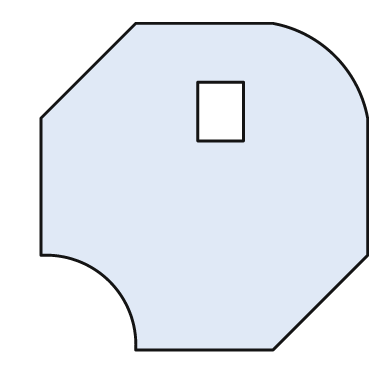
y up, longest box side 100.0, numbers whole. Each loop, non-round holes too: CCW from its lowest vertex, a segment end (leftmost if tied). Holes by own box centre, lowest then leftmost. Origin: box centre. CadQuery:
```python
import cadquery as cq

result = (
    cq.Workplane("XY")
    .moveTo(-21.0, -50.0)
    .lineTo(21.0, -50.0)
    .lineTo(50.0, -21.0)
    .lineTo(50.0, 21.0)
    .threePointArc((40.0, 40.0), (21.0, 50.0))
    .lineTo(-21.0, 50.0)
    .lineTo(-50.0, 21.0)
    .lineTo(-50.0, -21.0)
    .threePointArc((-29.0, -29.0), (-21.0, -50.0))
    .close()
    .moveTo(-2.0, 14.0)
    .lineTo(12.0, 14.0)
    .lineTo(12.0, 32.0)
    .lineTo(-2.0, 32.0)
    .close()
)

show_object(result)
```